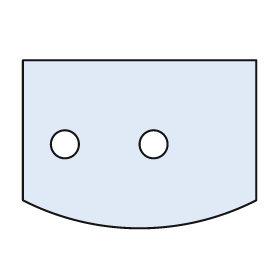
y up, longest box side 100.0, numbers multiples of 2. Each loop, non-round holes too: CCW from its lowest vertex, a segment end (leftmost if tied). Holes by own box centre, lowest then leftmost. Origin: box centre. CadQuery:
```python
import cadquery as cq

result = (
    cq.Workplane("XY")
    .moveTo(-50.0, -24.0)
    .threePointArc((0.0, -36.0), (50.0, -24.0))
    .lineTo(50.0, 36.0)
    .lineTo(-50.0, 36.0)
    .close()
    .moveTo(-32.0, 0.0)
    .circle(6.0)
    .moveTo(6.0, 0.0)
    .circle(6.0)
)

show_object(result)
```